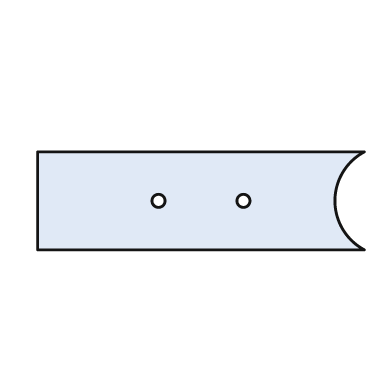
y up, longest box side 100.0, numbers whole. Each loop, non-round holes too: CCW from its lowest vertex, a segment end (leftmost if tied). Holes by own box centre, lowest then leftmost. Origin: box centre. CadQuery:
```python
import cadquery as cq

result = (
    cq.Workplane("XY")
    .moveTo(-50.0, -15.0)
    .lineTo(50.0, -15.0)
    .threePointArc((41.0, 0.0), (50.0, 15.0))
    .lineTo(-50.0, 15.0)
    .close()
    .moveTo(-13.0, 0.0)
    .circle(2.0)
    .moveTo(13.0, 0.0)
    .circle(2.0)
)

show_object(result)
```